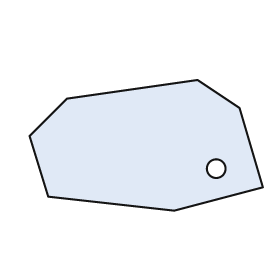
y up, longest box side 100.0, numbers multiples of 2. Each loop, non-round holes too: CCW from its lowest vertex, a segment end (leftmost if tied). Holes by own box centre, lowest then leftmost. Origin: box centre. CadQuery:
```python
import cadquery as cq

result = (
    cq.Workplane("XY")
    .moveTo(12.0, -28.0)
    .lineTo(50.0, -18.0)
    .lineTo(40.0, 16.0)
    .lineTo(22.0, 28.0)
    .lineTo(-34.0, 20.0)
    .lineTo(-50.0, 4.0)
    .lineTo(-42.0, -22.0)
    .close()
    .moveTo(30.0, -10.0)
    .circle(4.0)
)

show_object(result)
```